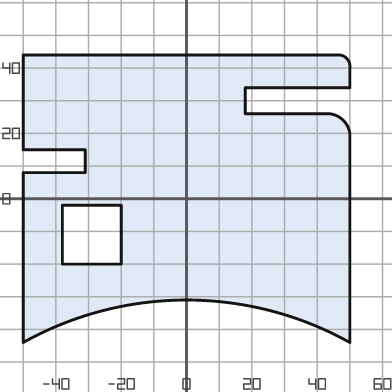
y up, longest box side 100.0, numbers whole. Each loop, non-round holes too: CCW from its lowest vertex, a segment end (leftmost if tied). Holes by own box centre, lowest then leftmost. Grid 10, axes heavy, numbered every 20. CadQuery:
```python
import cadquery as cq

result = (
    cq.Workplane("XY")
    .moveTo(-50.0, -44.0)
    .threePointArc((0.0, -31.0), (50.0, -44.0))
    .lineTo(50.0, 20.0)
    .threePointArc((48.0, 24.0), (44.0, 26.0))
    .lineTo(18.0, 26.0)
    .lineTo(18.0, 34.0)
    .lineTo(50.0, 34.0)
    .lineTo(50.0, 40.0)
    .threePointArc((49.0, 43.0), (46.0, 44.0))
    .lineTo(-50.0, 44.0)
    .lineTo(-50.0, 15.0)
    .lineTo(-31.0, 15.0)
    .lineTo(-31.0, 8.0)
    .lineTo(-50.0, 8.0)
    .close()
    .moveTo(-38.0, -20.0)
    .lineTo(-20.0, -20.0)
    .lineTo(-20.0, -2.0)
    .lineTo(-38.0, -2.0)
    .close()
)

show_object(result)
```